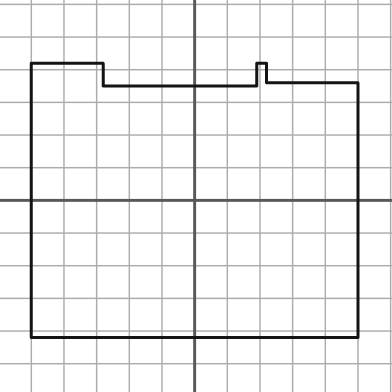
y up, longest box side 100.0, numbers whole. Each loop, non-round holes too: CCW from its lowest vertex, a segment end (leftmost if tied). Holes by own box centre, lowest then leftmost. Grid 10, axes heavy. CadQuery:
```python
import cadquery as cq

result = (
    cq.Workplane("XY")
    .moveTo(-50.0, -42.0)
    .lineTo(50.0, -42.0)
    .lineTo(50.0, 36.0)
    .lineTo(22.0, 36.0)
    .lineTo(22.0, 42.0)
    .lineTo(19.0, 42.0)
    .lineTo(19.0, 35.0)
    .lineTo(-28.0, 35.0)
    .lineTo(-28.0, 42.0)
    .lineTo(-50.0, 42.0)
    .close()
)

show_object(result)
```